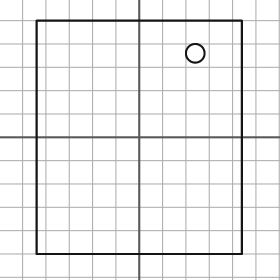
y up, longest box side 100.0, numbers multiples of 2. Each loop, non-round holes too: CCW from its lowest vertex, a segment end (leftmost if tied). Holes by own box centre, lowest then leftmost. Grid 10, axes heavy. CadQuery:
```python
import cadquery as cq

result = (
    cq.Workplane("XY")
    .moveTo(-44.0, -50.0)
    .lineTo(44.0, -50.0)
    .lineTo(44.0, 50.0)
    .lineTo(-44.0, 50.0)
    .close()
    .moveTo(24.0, 36.0)
    .circle(4.0)
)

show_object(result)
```